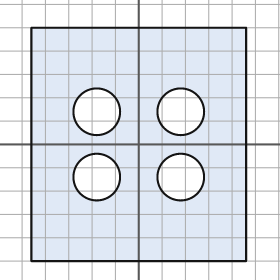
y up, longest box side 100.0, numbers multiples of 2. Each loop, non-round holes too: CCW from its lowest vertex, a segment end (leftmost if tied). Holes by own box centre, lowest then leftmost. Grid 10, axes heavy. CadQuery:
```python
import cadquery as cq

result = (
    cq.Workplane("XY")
    .moveTo(-46.0, -50.0)
    .lineTo(46.0, -50.0)
    .lineTo(46.0, 50.0)
    .lineTo(-46.0, 50.0)
    .close()
    .moveTo(-18.0, -14.0)
    .circle(10.0)
    .moveTo(18.0, -14.0)
    .circle(10.0)
    .moveTo(-18.0, 14.0)
    .circle(10.0)
    .moveTo(18.0, 14.0)
    .circle(10.0)
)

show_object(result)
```